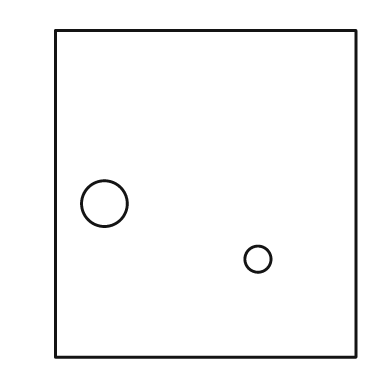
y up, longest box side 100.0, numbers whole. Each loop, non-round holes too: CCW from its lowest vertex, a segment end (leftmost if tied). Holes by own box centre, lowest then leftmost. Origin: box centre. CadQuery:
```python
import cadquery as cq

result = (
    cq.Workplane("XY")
    .moveTo(-46.0, -50.0)
    .lineTo(46.0, -50.0)
    .lineTo(46.0, 50.0)
    .lineTo(-46.0, 50.0)
    .close()
    .moveTo(16.0, -20.0)
    .circle(4.0)
    .moveTo(-31.0, -3.0)
    .circle(7.0)
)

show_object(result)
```